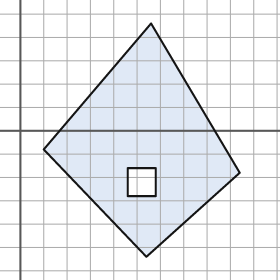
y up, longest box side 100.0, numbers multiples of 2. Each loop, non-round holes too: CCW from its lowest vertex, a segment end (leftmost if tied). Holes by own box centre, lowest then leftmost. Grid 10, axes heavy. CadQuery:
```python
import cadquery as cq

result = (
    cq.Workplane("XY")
    .moveTo(54.0, -54.0)
    .lineTo(94.0, -18.0)
    .lineTo(56.0, 46.0)
    .lineTo(10.0, -8.0)
    .close()
    .moveTo(46.0, -28.0)
    .lineTo(58.0, -28.0)
    .lineTo(58.0, -16.0)
    .lineTo(46.0, -16.0)
    .close()
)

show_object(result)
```